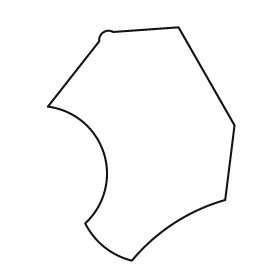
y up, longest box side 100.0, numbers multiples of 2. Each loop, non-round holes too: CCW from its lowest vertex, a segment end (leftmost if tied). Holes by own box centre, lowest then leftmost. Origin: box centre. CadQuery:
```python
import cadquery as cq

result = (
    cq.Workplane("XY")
    .moveTo(-4.0, -50.0)
    .threePointArc((14.0, -34.0), (36.0, -24.0))
    .lineTo(40.0, 8.0)
    .lineTo(16.0, 50.0)
    .lineTo(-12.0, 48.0)
    .threePointArc((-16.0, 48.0), (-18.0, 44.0))
    .lineTo(-40.0, 16.0)
    .threePointArc((-16.0, -4.0), (-24.0, -34.0))
    .threePointArc((-16.0, -44.0), (-4.0, -50.0))
    .close()
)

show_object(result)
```